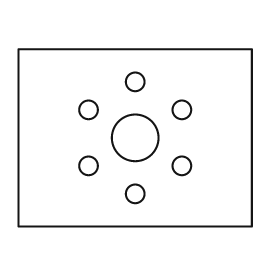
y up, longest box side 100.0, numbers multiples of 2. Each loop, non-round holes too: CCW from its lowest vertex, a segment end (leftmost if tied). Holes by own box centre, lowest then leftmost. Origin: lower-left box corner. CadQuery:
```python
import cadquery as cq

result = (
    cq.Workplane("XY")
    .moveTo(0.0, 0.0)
    .lineTo(100.0, 0.0)
    .lineTo(100.0, 76.0)
    .lineTo(0.0, 76.0)
    .close()
    .moveTo(50.0, 14.0)
    .circle(4.0)
    .moveTo(30.0, 26.0)
    .circle(4.0)
    .moveTo(70.0, 26.0)
    .circle(4.0)
    .moveTo(50.0, 38.0)
    .circle(10.0)
    .moveTo(30.0, 50.0)
    .circle(4.0)
    .moveTo(70.0, 50.0)
    .circle(4.0)
    .moveTo(50.0, 62.0)
    .circle(4.0)
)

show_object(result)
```